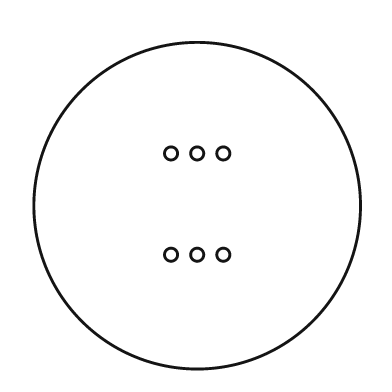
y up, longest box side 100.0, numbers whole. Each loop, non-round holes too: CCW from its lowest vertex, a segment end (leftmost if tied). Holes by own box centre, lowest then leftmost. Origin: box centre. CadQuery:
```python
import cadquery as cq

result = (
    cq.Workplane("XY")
    .moveTo(0.0, 0.0)
    .circle(50.0)
    .moveTo(-8.0, -15.0)
    .circle(2.0)
    .moveTo(0.0, -15.0)
    .circle(2.0)
    .moveTo(8.0, -15.0)
    .circle(2.0)
    .moveTo(-8.0, 16.0)
    .circle(2.0)
    .moveTo(0.0, 16.0)
    .circle(2.0)
    .moveTo(8.0, 16.0)
    .circle(2.0)
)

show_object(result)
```